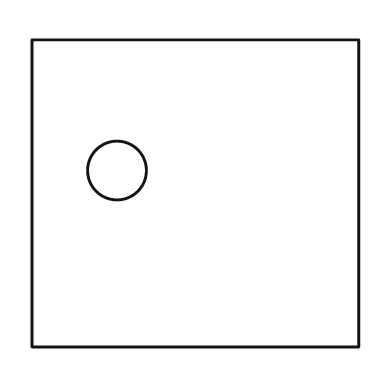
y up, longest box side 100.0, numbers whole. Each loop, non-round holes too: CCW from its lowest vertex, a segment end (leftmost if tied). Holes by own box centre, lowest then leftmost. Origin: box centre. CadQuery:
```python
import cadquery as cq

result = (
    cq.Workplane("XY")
    .moveTo(-50.0, -47.0)
    .lineTo(50.0, -47.0)
    .lineTo(50.0, 47.0)
    .lineTo(-50.0, 47.0)
    .close()
    .moveTo(-24.0, 7.0)
    .circle(9.0)
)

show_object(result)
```